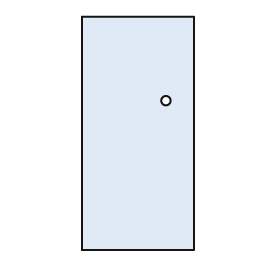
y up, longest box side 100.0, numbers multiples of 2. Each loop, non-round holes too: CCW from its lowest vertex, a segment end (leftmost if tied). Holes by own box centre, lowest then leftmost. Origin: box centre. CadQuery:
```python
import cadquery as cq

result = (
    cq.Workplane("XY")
    .moveTo(-24.0, -50.0)
    .lineTo(24.0, -50.0)
    .lineTo(24.0, 50.0)
    .lineTo(-24.0, 50.0)
    .close()
    .moveTo(12.0, 14.0)
    .circle(2.0)
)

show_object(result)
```